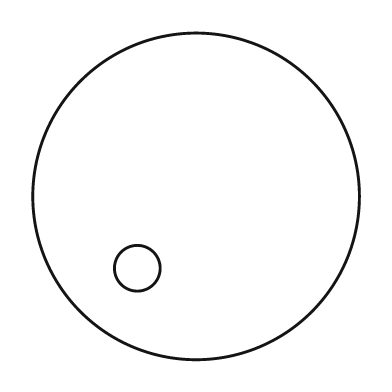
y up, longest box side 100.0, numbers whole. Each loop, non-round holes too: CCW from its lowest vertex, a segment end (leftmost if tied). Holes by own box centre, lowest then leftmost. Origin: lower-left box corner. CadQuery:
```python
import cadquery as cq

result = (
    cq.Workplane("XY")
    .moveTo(50.0, 50.0)
    .circle(50.0)
    .moveTo(32.0, 28.0)
    .circle(7.0)
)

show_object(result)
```